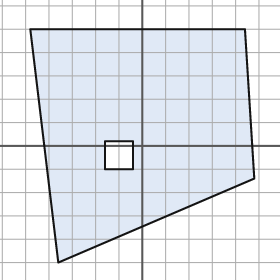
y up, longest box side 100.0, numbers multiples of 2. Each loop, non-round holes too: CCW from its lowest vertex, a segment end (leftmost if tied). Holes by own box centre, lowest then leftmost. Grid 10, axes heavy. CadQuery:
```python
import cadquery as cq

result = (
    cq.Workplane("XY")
    .moveTo(-36.0, -50.0)
    .lineTo(48.0, -14.0)
    .lineTo(44.0, 50.0)
    .lineTo(-48.0, 50.0)
    .close()
    .moveTo(-16.0, -10.0)
    .lineTo(-4.0, -10.0)
    .lineTo(-4.0, 2.0)
    .lineTo(-16.0, 2.0)
    .close()
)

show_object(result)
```